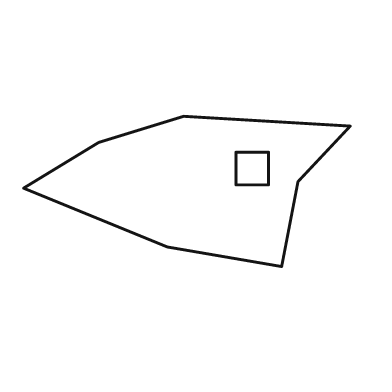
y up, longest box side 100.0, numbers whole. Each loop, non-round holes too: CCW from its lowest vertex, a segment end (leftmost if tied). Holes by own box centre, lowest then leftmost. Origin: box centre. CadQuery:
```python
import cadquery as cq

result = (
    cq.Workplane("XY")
    .moveTo(29.0, -23.0)
    .lineTo(34.0, 3.0)
    .lineTo(50.0, 20.0)
    .lineTo(-1.0, 23.0)
    .lineTo(-27.0, 15.0)
    .lineTo(-50.0, 1.0)
    .lineTo(-6.0, -17.0)
    .close()
    .moveTo(15.0, 2.0)
    .lineTo(25.0, 2.0)
    .lineTo(25.0, 12.0)
    .lineTo(15.0, 12.0)
    .close()
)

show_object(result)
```